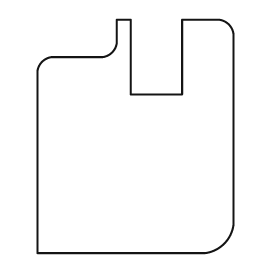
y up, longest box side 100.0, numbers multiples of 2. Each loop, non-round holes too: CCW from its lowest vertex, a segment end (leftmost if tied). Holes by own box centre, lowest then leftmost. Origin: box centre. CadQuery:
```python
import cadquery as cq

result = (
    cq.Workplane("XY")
    .moveTo(-42.0, -50.0)
    .lineTo(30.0, -50.0)
    .threePointArc((38.0, -46.0), (42.0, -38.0))
    .lineTo(42.0, 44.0)
    .threePointArc((40.0, 48.0), (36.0, 50.0))
    .lineTo(20.0, 50.0)
    .lineTo(20.0, 18.0)
    .lineTo(-2.0, 18.0)
    .lineTo(-2.0, 50.0)
    .lineTo(-8.0, 50.0)
    .lineTo(-8.0, 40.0)
    .threePointArc((-10.0, 36.0), (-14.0, 34.0))
    .lineTo(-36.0, 34.0)
    .threePointArc((-40.0, 32.0), (-42.0, 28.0))
    .close()
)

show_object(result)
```